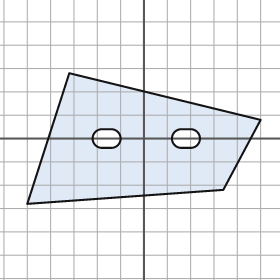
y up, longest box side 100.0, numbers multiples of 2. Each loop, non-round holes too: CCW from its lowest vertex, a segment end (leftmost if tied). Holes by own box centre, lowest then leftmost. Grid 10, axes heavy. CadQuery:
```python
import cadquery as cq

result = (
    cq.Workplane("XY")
    .moveTo(-50.0, -28.0)
    .lineTo(34.0, -22.0)
    .lineTo(50.0, 8.0)
    .lineTo(-32.0, 28.0)
    .close()
    .moveTo(-18.0, -4.0)
    .lineTo(-14.0, -4.0)
    .threePointArc((-10.0, 0.0), (-14.0, 4.0))
    .lineTo(-18.0, 4.0)
    .threePointArc((-22.0, 0.0), (-18.0, -4.0))
    .close()
    .moveTo(16.0, -4.0)
    .lineTo(20.0, -4.0)
    .threePointArc((24.0, 0.0), (20.0, 4.0))
    .lineTo(16.0, 4.0)
    .threePointArc((12.0, 0.0), (16.0, -4.0))
    .close()
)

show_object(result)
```